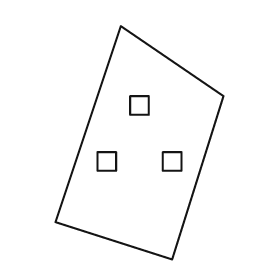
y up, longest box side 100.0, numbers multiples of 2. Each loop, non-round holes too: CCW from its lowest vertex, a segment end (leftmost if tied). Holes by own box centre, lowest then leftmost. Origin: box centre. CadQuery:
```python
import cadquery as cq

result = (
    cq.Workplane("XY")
    .moveTo(14.0, -50.0)
    .lineTo(36.0, 20.0)
    .lineTo(-8.0, 50.0)
    .lineTo(-36.0, -34.0)
    .close()
    .moveTo(-18.0, -12.0)
    .lineTo(-10.0, -12.0)
    .lineTo(-10.0, -4.0)
    .lineTo(-18.0, -4.0)
    .close()
    .moveTo(10.0, -12.0)
    .lineTo(18.0, -12.0)
    .lineTo(18.0, -4.0)
    .lineTo(10.0, -4.0)
    .close()
    .moveTo(-4.0, 12.0)
    .lineTo(4.0, 12.0)
    .lineTo(4.0, 20.0)
    .lineTo(-4.0, 20.0)
    .close()
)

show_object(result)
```